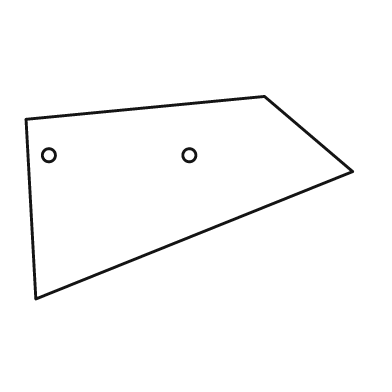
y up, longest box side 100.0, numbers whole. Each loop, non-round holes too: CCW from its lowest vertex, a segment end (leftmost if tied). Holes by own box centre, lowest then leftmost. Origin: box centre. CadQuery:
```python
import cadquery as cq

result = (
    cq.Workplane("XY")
    .moveTo(-47.0, -31.0)
    .lineTo(50.0, 8.0)
    .lineTo(23.0, 31.0)
    .lineTo(-50.0, 24.0)
    .close()
    .moveTo(-43.0, 13.0)
    .circle(2.0)
    .moveTo(0.0, 13.0)
    .circle(2.0)
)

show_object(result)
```